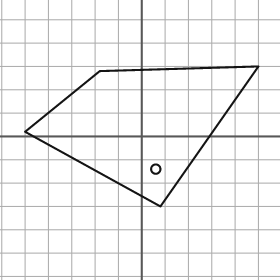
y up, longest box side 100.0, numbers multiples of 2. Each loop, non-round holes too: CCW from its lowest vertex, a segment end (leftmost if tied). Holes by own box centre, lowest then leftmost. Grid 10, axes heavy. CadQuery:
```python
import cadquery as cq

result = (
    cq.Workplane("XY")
    .moveTo(8.0, -30.0)
    .lineTo(50.0, 30.0)
    .lineTo(-18.0, 28.0)
    .lineTo(-50.0, 2.0)
    .close()
    .moveTo(6.0, -14.0)
    .circle(2.0)
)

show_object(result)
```